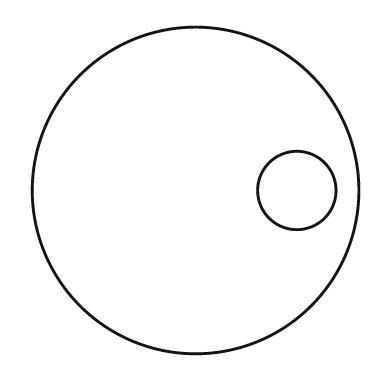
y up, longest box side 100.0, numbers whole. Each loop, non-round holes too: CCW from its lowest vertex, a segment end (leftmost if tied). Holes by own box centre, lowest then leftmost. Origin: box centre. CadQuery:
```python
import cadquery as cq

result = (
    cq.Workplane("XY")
    .moveTo(0.0, 0.0)
    .circle(50.0)
    .moveTo(31.0, 0.0)
    .circle(12.0)
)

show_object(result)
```